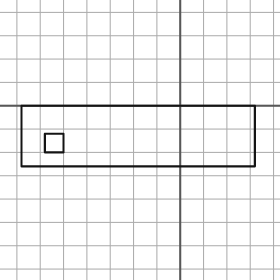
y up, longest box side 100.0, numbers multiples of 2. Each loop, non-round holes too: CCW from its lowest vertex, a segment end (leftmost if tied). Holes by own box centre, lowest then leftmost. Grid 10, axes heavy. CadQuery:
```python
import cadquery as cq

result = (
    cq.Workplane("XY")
    .moveTo(-68.0, -26.0)
    .lineTo(32.0, -26.0)
    .lineTo(32.0, 0.0)
    .lineTo(-68.0, 0.0)
    .close()
    .moveTo(-58.0, -20.0)
    .lineTo(-50.0, -20.0)
    .lineTo(-50.0, -12.0)
    .lineTo(-58.0, -12.0)
    .close()
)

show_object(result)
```